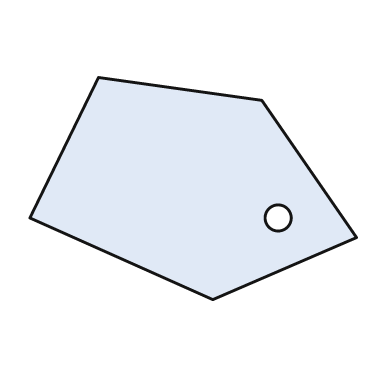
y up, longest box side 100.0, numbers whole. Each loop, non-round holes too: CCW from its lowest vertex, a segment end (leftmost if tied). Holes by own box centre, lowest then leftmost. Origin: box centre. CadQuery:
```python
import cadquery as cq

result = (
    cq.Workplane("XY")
    .moveTo(6.0, -34.0)
    .lineTo(50.0, -15.0)
    .lineTo(21.0, 27.0)
    .lineTo(-29.0, 34.0)
    .lineTo(-50.0, -9.0)
    .close()
    .moveTo(26.0, -9.0)
    .circle(4.0)
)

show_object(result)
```